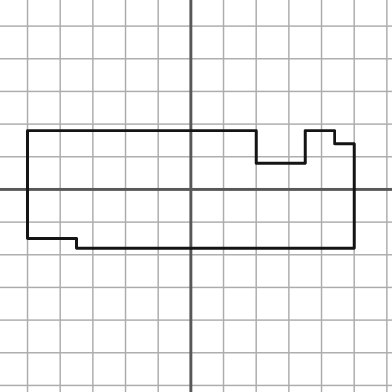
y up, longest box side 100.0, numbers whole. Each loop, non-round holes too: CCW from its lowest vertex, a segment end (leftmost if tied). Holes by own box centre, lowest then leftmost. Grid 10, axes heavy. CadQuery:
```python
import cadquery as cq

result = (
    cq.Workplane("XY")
    .moveTo(-35.0, -18.0)
    .lineTo(50.0, -18.0)
    .lineTo(50.0, 14.0)
    .lineTo(44.0, 14.0)
    .lineTo(44.0, 18.0)
    .lineTo(35.0, 18.0)
    .lineTo(35.0, 8.0)
    .lineTo(20.0, 8.0)
    .lineTo(20.0, 18.0)
    .lineTo(-50.0, 18.0)
    .lineTo(-50.0, -15.0)
    .lineTo(-35.0, -15.0)
    .close()
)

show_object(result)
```